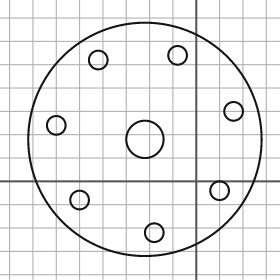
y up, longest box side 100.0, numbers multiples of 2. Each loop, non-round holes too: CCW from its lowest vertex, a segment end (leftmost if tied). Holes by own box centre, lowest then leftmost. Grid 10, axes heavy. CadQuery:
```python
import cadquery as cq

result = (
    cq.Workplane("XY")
    .moveTo(-22.0, 18.0)
    .circle(50.0)
    .moveTo(-18.0, -22.0)
    .circle(4.0)
    .moveTo(-50.0, -8.0)
    .circle(4.0)
    .moveTo(10.0, -4.0)
    .circle(4.0)
    .moveTo(-22.0, 18.0)
    .circle(8.0)
    .moveTo(-60.0, 24.0)
    .circle(4.0)
    .moveTo(16.0, 30.0)
    .circle(4.0)
    .moveTo(-42.0, 52.0)
    .circle(4.0)
    .moveTo(-8.0, 54.0)
    .circle(4.0)
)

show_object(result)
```